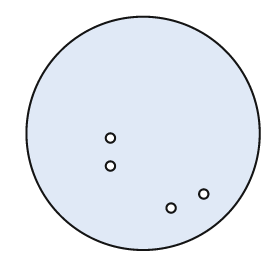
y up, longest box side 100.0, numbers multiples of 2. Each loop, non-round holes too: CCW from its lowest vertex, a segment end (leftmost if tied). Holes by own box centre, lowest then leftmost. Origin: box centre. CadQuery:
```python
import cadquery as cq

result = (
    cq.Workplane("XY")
    .moveTo(0.0, 0.0)
    .circle(50.0)
    .moveTo(12.0, -32.0)
    .circle(2.0)
    .moveTo(26.0, -26.0)
    .circle(2.0)
    .moveTo(-14.0, -14.0)
    .circle(2.0)
    .moveTo(-14.0, -2.0)
    .circle(2.0)
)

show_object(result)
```